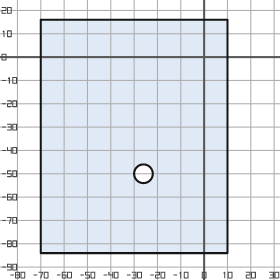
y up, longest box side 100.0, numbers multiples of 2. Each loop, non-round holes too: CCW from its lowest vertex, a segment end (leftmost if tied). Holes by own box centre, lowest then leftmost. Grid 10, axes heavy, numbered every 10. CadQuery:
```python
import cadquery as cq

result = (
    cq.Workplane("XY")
    .moveTo(-70.0, -84.0)
    .lineTo(10.0, -84.0)
    .lineTo(10.0, 16.0)
    .lineTo(-70.0, 16.0)
    .close()
    .moveTo(-26.0, -50.0)
    .circle(4.0)
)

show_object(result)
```